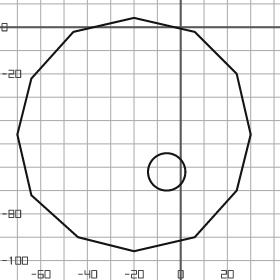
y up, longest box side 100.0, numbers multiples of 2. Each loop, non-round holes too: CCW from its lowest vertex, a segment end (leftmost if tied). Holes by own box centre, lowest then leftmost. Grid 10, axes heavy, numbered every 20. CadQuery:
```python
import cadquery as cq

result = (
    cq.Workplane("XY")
    .moveTo(-20.0, -96.0)
    .lineTo(6.0, -90.0)
    .lineTo(24.0, -70.0)
    .lineTo(30.0, -46.0)
    .lineTo(24.0, -20.0)
    .lineTo(6.0, -2.0)
    .lineTo(-20.0, 4.0)
    .lineTo(-46.0, -2.0)
    .lineTo(-64.0, -22.0)
    .lineTo(-70.0, -46.0)
    .lineTo(-64.0, -72.0)
    .lineTo(-44.0, -90.0)
    .close()
    .moveTo(-6.0, -62.0)
    .circle(8.0)
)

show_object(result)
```